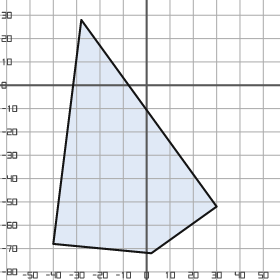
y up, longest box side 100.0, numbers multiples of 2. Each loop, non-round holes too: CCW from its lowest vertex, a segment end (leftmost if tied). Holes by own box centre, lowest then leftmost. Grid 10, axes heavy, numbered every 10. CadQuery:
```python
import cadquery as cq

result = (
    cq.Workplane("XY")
    .moveTo(2.0, -72.0)
    .lineTo(30.0, -52.0)
    .lineTo(-28.0, 28.0)
    .lineTo(-40.0, -68.0)
    .close()
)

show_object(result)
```